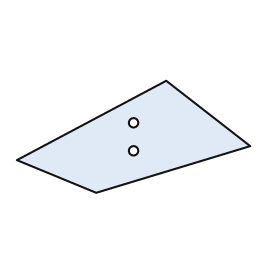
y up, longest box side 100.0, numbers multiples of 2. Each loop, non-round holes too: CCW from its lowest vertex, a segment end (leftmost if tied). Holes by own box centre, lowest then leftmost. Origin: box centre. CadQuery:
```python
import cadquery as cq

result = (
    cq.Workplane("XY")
    .moveTo(-16.0, -24.0)
    .lineTo(50.0, -4.0)
    .lineTo(14.0, 24.0)
    .lineTo(-50.0, -10.0)
    .close()
    .moveTo(0.0, -6.0)
    .circle(2.0)
    .moveTo(0.0, 6.0)
    .circle(2.0)
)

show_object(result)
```